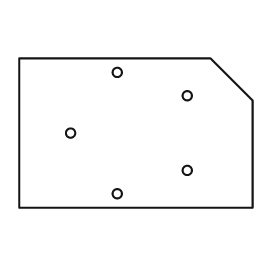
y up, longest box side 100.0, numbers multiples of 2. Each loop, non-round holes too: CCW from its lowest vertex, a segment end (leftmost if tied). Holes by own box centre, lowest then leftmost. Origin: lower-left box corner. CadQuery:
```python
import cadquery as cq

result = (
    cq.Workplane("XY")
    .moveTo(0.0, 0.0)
    .lineTo(100.0, 0.0)
    .lineTo(100.0, 46.0)
    .lineTo(82.0, 64.0)
    .lineTo(0.0, 64.0)
    .close()
    .moveTo(42.0, 6.0)
    .circle(2.0)
    .moveTo(72.0, 16.0)
    .circle(2.0)
    .moveTo(22.0, 32.0)
    .circle(2.0)
    .moveTo(72.0, 48.0)
    .circle(2.0)
    .moveTo(42.0, 58.0)
    .circle(2.0)
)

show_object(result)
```